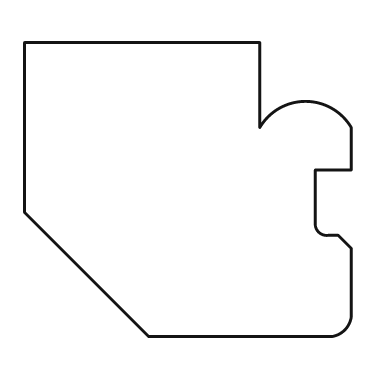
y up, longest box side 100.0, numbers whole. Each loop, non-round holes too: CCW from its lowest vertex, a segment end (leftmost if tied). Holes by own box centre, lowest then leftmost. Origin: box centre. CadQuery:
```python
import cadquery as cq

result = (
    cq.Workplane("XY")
    .moveTo(-12.0, -45.0)
    .lineTo(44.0, -45.0)
    .threePointArc((48.0, -43.0), (50.0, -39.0))
    .lineTo(50.0, -18.0)
    .lineTo(46.0, -14.0)
    .lineTo(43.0, -14.0)
    .threePointArc((40.0, -13.0), (39.0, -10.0))
    .lineTo(39.0, 6.0)
    .lineTo(50.0, 6.0)
    .lineTo(50.0, 19.0)
    .threePointArc((36.0, 27.0), (22.0, 19.0))
    .lineTo(22.0, 45.0)
    .lineTo(-50.0, 45.0)
    .lineTo(-50.0, -7.0)
    .close()
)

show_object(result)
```